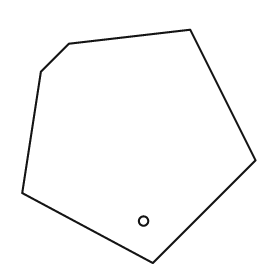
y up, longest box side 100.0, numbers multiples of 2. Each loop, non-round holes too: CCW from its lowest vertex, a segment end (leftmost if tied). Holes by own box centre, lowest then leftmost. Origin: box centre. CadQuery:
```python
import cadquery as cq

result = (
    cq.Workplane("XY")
    .moveTo(6.0, -50.0)
    .lineTo(50.0, -6.0)
    .lineTo(22.0, 50.0)
    .lineTo(-30.0, 44.0)
    .lineTo(-42.0, 32.0)
    .lineTo(-50.0, -20.0)
    .close()
    .moveTo(2.0, -32.0)
    .circle(2.0)
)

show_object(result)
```